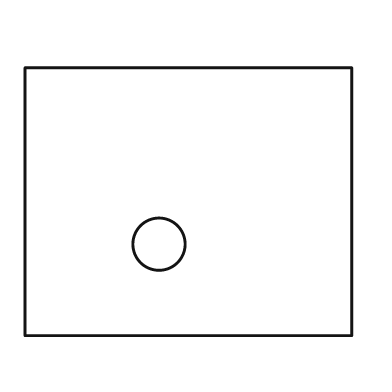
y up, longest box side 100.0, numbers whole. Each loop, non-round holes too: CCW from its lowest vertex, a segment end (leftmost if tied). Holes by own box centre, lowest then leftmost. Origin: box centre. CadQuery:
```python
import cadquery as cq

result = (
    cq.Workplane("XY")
    .moveTo(-50.0, -41.0)
    .lineTo(50.0, -41.0)
    .lineTo(50.0, 41.0)
    .lineTo(-50.0, 41.0)
    .close()
    .moveTo(-9.0, -13.0)
    .circle(8.0)
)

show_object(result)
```